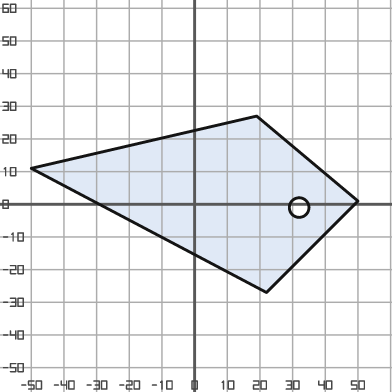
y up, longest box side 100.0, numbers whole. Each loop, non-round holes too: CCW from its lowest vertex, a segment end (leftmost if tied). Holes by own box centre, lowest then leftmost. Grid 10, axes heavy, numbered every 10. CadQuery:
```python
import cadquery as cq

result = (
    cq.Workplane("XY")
    .moveTo(22.0, -27.0)
    .lineTo(50.0, 1.0)
    .lineTo(19.0, 27.0)
    .lineTo(-50.0, 11.0)
    .close()
    .moveTo(32.0, -1.0)
    .circle(3.0)
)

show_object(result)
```